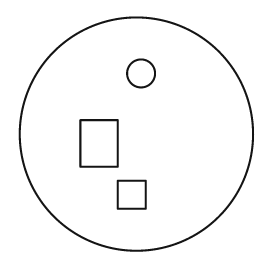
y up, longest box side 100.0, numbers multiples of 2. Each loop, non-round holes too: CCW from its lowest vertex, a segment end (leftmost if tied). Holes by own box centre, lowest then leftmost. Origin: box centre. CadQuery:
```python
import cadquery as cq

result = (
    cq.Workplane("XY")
    .moveTo(0.0, 0.0)
    .circle(50.0)
    .moveTo(-8.0, -32.0)
    .lineTo(4.0, -32.0)
    .lineTo(4.0, -20.0)
    .lineTo(-8.0, -20.0)
    .close()
    .moveTo(-24.0, -14.0)
    .lineTo(-8.0, -14.0)
    .lineTo(-8.0, 6.0)
    .lineTo(-24.0, 6.0)
    .close()
    .moveTo(2.0, 26.0)
    .circle(6.0)
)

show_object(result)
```